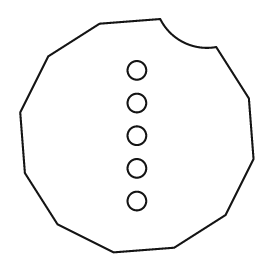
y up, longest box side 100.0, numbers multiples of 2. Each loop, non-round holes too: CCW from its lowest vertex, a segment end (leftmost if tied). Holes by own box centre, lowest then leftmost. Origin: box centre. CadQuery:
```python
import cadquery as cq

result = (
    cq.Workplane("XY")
    .moveTo(-10.0, -50.0)
    .lineTo(16.0, -48.0)
    .lineTo(38.0, -34.0)
    .lineTo(50.0, -10.0)
    .lineTo(48.0, 16.0)
    .lineTo(34.0, 38.0)
    .threePointArc((20.0, 40.0), (10.0, 50.0))
    .lineTo(-16.0, 48.0)
    .lineTo(-38.0, 34.0)
    .lineTo(-50.0, 10.0)
    .lineTo(-48.0, -16.0)
    .lineTo(-34.0, -38.0)
    .close()
    .moveTo(0.0, -28.0)
    .circle(4.0)
    .moveTo(0.0, -14.0)
    .circle(4.0)
    .moveTo(0.0, 0.0)
    .circle(4.0)
    .moveTo(0.0, 14.0)
    .circle(4.0)
    .moveTo(0.0, 28.0)
    .circle(4.0)
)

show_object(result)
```